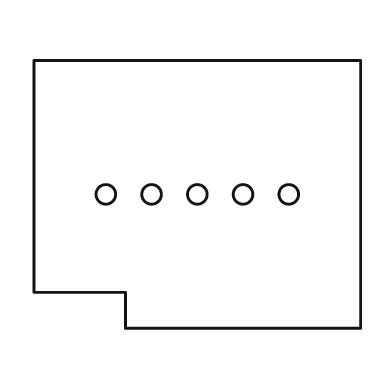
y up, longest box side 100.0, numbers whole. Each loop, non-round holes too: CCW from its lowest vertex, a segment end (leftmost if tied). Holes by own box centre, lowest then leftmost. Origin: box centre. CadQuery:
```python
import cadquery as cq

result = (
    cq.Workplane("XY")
    .moveTo(-22.0, -41.0)
    .lineTo(50.0, -41.0)
    .lineTo(50.0, 41.0)
    .lineTo(-50.0, 41.0)
    .lineTo(-50.0, -30.0)
    .lineTo(-22.0, -30.0)
    .close()
    .moveTo(-28.0, 0.0)
    .circle(3.0)
    .moveTo(-14.0, 0.0)
    .circle(3.0)
    .moveTo(0.0, 0.0)
    .circle(3.0)
    .moveTo(14.0, 0.0)
    .circle(3.0)
    .moveTo(28.0, 0.0)
    .circle(3.0)
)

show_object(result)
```